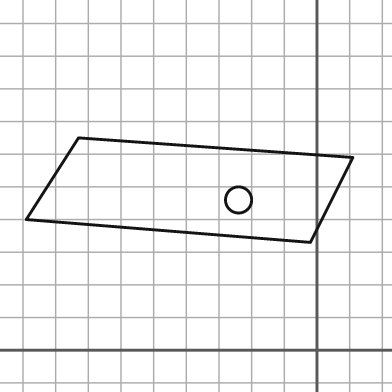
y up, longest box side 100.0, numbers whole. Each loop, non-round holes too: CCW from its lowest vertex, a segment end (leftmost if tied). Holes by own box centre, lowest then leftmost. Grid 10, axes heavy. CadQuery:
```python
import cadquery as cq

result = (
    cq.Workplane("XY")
    .moveTo(-2.0, 33.0)
    .lineTo(11.0, 59.0)
    .lineTo(-73.0, 65.0)
    .lineTo(-89.0, 40.0)
    .close()
    .moveTo(-24.0, 46.0)
    .circle(4.0)
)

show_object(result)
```